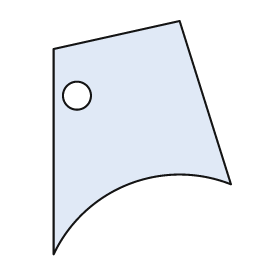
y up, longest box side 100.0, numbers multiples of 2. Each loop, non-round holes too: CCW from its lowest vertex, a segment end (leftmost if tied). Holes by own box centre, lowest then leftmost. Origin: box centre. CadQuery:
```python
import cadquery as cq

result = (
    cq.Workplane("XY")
    .moveTo(-38.0, -50.0)
    .threePointArc((-6.0, -20.0), (38.0, -20.0))
    .lineTo(16.0, 50.0)
    .lineTo(-38.0, 38.0)
    .close()
    .moveTo(-28.0, 18.0)
    .circle(6.0)
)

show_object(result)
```